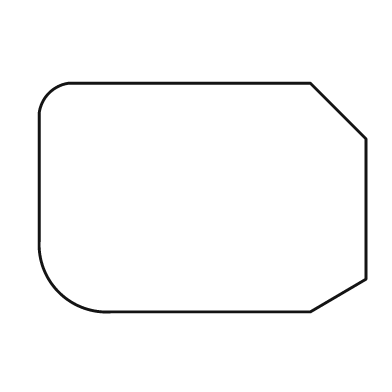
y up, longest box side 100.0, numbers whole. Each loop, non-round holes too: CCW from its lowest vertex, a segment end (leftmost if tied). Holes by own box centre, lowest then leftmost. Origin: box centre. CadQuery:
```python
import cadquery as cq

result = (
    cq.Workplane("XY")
    .moveTo(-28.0, -35.0)
    .lineTo(33.0, -35.0)
    .lineTo(50.0, -25.0)
    .lineTo(50.0, 18.0)
    .lineTo(33.0, 35.0)
    .lineTo(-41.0, 35.0)
    .threePointArc((-47.0, 32.0), (-50.0, 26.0))
    .lineTo(-50.0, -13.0)
    .threePointArc((-44.0, -29.0), (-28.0, -35.0))
    .close()
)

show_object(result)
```